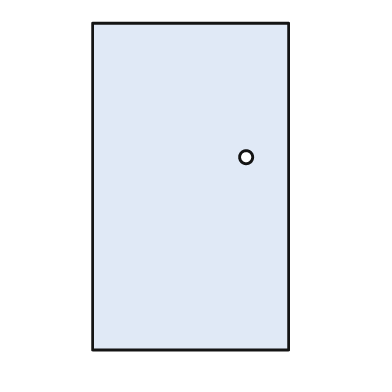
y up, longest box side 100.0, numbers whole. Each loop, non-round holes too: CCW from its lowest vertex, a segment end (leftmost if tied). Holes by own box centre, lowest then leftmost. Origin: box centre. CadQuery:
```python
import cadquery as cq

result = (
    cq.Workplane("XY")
    .moveTo(-30.0, -50.0)
    .lineTo(30.0, -50.0)
    .lineTo(30.0, 50.0)
    .lineTo(-30.0, 50.0)
    .close()
    .moveTo(17.0, 9.0)
    .circle(2.0)
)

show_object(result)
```